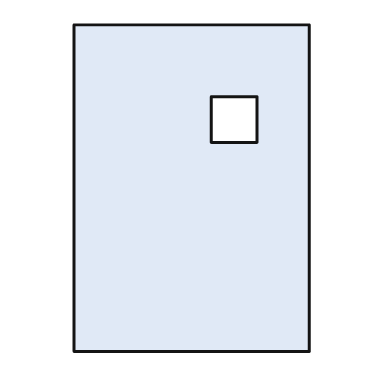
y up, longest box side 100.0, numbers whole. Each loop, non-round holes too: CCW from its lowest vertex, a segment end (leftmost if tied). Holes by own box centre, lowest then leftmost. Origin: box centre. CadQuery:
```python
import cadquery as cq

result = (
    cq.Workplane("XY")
    .moveTo(-36.0, -50.0)
    .lineTo(36.0, -50.0)
    .lineTo(36.0, 50.0)
    .lineTo(-36.0, 50.0)
    .close()
    .moveTo(6.0, 14.0)
    .lineTo(20.0, 14.0)
    .lineTo(20.0, 28.0)
    .lineTo(6.0, 28.0)
    .close()
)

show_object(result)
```